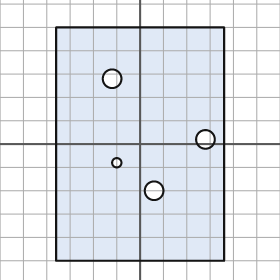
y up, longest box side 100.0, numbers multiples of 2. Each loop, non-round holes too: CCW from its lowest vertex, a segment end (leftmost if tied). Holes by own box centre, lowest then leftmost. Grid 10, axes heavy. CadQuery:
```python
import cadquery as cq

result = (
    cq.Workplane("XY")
    .moveTo(-36.0, -50.0)
    .lineTo(36.0, -50.0)
    .lineTo(36.0, 50.0)
    .lineTo(-36.0, 50.0)
    .close()
    .moveTo(6.0, -20.0)
    .circle(4.0)
    .moveTo(-10.0, -8.0)
    .circle(2.0)
    .moveTo(28.0, 2.0)
    .circle(4.0)
    .moveTo(-12.0, 28.0)
    .circle(4.0)
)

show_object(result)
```